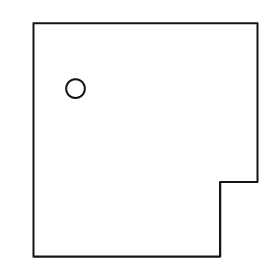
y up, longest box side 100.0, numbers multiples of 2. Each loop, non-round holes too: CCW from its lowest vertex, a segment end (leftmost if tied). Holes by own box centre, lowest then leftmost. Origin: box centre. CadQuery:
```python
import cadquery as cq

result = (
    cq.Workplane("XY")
    .moveTo(-48.0, -50.0)
    .lineTo(32.0, -50.0)
    .lineTo(32.0, -18.0)
    .lineTo(48.0, -18.0)
    .lineTo(48.0, 50.0)
    .lineTo(-48.0, 50.0)
    .close()
    .moveTo(-30.0, 22.0)
    .circle(4.0)
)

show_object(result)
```